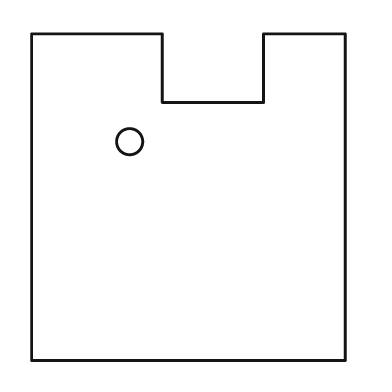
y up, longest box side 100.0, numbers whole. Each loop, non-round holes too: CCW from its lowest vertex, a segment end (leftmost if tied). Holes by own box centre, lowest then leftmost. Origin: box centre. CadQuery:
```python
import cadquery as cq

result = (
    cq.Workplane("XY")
    .moveTo(-48.0, -50.0)
    .lineTo(48.0, -50.0)
    .lineTo(48.0, 50.0)
    .lineTo(23.0, 50.0)
    .lineTo(23.0, 29.0)
    .lineTo(-8.0, 29.0)
    .lineTo(-8.0, 50.0)
    .lineTo(-48.0, 50.0)
    .close()
    .moveTo(-18.0, 17.0)
    .circle(4.0)
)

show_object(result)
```